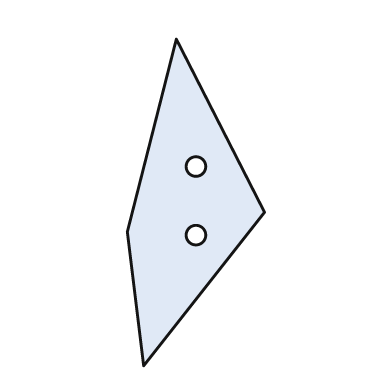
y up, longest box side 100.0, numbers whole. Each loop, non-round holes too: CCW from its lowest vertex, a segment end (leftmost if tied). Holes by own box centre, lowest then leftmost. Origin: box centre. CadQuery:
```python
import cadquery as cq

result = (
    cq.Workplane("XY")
    .moveTo(-16.0, -50.0)
    .lineTo(21.0, -3.0)
    .lineTo(-6.0, 50.0)
    .lineTo(-21.0, -9.0)
    .close()
    .moveTo(0.0, -10.0)
    .circle(3.0)
    .moveTo(0.0, 11.0)
    .circle(3.0)
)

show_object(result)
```